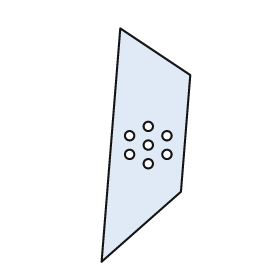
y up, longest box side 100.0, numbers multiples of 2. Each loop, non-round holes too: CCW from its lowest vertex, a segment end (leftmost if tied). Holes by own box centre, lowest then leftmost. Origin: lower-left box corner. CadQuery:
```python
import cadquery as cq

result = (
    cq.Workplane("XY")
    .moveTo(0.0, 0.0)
    .lineTo(34.0, 30.0)
    .lineTo(38.0, 80.0)
    .lineTo(8.0, 100.0)
    .close()
    .moveTo(20.0, 42.0)
    .circle(2.0)
    .moveTo(12.0, 46.0)
    .circle(2.0)
    .moveTo(28.0, 46.0)
    .circle(2.0)
    .moveTo(20.0, 50.0)
    .circle(2.0)
    .moveTo(12.0, 54.0)
    .circle(2.0)
    .moveTo(28.0, 54.0)
    .circle(2.0)
    .moveTo(20.0, 58.0)
    .circle(2.0)
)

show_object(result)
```